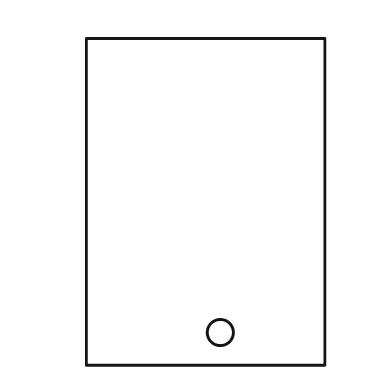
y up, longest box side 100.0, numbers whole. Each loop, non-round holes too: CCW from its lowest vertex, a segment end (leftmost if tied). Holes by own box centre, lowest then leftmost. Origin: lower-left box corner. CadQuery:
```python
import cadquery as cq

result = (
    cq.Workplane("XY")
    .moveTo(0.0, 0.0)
    .lineTo(73.0, 0.0)
    .lineTo(73.0, 100.0)
    .lineTo(0.0, 100.0)
    .close()
    .moveTo(41.0, 10.0)
    .circle(4.0)
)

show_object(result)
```